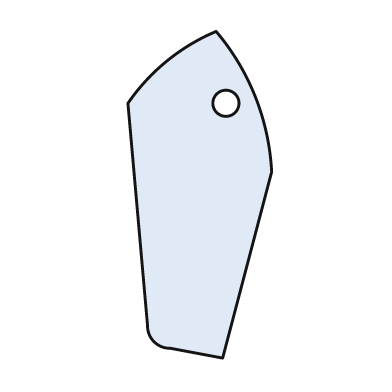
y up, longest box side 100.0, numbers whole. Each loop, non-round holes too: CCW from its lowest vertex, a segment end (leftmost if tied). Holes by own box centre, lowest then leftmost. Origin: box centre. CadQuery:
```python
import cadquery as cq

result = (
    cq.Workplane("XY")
    .moveTo(7.0, -50.0)
    .lineTo(22.0, 7.0)
    .threePointArc((17.0, 30.0), (5.0, 50.0))
    .threePointArc((-10.0, 41.0), (-22.0, 28.0))
    .lineTo(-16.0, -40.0)
    .threePointArc((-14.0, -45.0), (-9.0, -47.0))
    .close()
    .moveTo(8.0, 28.0)
    .circle(4.0)
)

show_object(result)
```